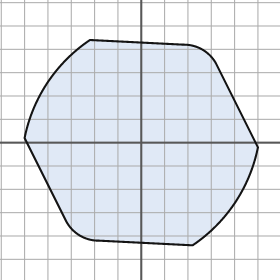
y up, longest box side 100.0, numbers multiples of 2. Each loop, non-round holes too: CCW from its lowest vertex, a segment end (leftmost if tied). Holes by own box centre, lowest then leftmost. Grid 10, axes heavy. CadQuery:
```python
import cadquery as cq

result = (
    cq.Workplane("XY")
    .moveTo(22.0, -44.0)
    .threePointArc((40.0, -26.0), (50.0, -2.0))
    .lineTo(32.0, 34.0)
    .threePointArc((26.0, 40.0), (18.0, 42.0))
    .lineTo(-22.0, 44.0)
    .threePointArc((-40.0, 26.0), (-50.0, 2.0))
    .lineTo(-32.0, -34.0)
    .threePointArc((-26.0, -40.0), (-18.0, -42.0))
    .close()
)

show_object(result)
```